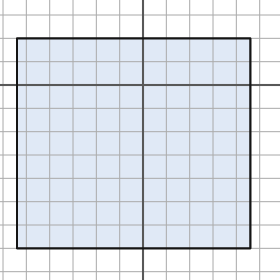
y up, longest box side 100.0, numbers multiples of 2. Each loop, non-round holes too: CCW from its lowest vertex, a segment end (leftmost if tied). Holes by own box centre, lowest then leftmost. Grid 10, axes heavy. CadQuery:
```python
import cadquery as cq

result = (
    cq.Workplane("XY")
    .moveTo(-54.0, -70.0)
    .lineTo(46.0, -70.0)
    .lineTo(46.0, 20.0)
    .lineTo(-54.0, 20.0)
    .close()
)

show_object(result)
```